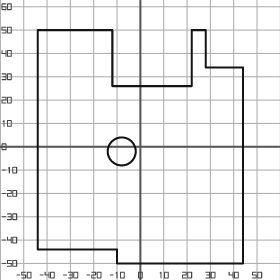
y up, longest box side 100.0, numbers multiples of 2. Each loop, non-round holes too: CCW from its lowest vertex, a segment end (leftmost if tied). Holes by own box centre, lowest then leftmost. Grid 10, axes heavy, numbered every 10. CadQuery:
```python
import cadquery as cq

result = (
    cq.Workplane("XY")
    .moveTo(-10.0, -50.0)
    .lineTo(44.0, -50.0)
    .lineTo(44.0, 34.0)
    .lineTo(28.0, 34.0)
    .lineTo(28.0, 50.0)
    .lineTo(22.0, 50.0)
    .lineTo(22.0, 26.0)
    .lineTo(-12.0, 26.0)
    .lineTo(-12.0, 50.0)
    .lineTo(-44.0, 50.0)
    .lineTo(-44.0, -44.0)
    .lineTo(-10.0, -44.0)
    .close()
    .moveTo(-8.0, -2.0)
    .circle(6.0)
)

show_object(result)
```